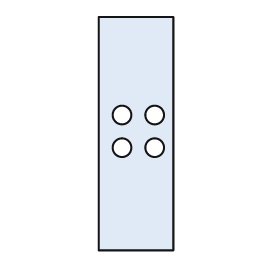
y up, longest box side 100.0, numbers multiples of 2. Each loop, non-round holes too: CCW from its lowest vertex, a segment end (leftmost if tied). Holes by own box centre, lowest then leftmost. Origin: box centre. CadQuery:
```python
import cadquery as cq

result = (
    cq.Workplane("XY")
    .moveTo(-16.0, -50.0)
    .lineTo(16.0, -50.0)
    .lineTo(16.0, 50.0)
    .lineTo(-16.0, 50.0)
    .close()
    .moveTo(-6.0, -6.0)
    .circle(4.0)
    .moveTo(8.0, -6.0)
    .circle(4.0)
    .moveTo(-6.0, 8.0)
    .circle(4.0)
    .moveTo(8.0, 8.0)
    .circle(4.0)
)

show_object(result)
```